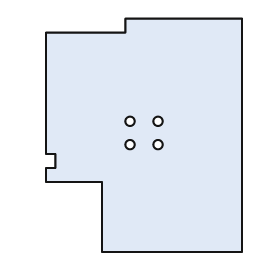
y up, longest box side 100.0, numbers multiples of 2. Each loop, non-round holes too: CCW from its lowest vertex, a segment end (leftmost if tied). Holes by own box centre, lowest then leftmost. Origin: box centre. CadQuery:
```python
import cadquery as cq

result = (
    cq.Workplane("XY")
    .moveTo(-18.0, -50.0)
    .lineTo(42.0, -50.0)
    .lineTo(42.0, 50.0)
    .lineTo(-8.0, 50.0)
    .lineTo(-8.0, 44.0)
    .lineTo(-42.0, 44.0)
    .lineTo(-42.0, -8.0)
    .lineTo(-38.0, -8.0)
    .lineTo(-38.0, -14.0)
    .lineTo(-42.0, -14.0)
    .lineTo(-42.0, -20.0)
    .lineTo(-18.0, -20.0)
    .close()
    .moveTo(-6.0, -4.0)
    .circle(2.0)
    .moveTo(6.0, -4.0)
    .circle(2.0)
    .moveTo(-6.0, 6.0)
    .circle(2.0)
    .moveTo(6.0, 6.0)
    .circle(2.0)
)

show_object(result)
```